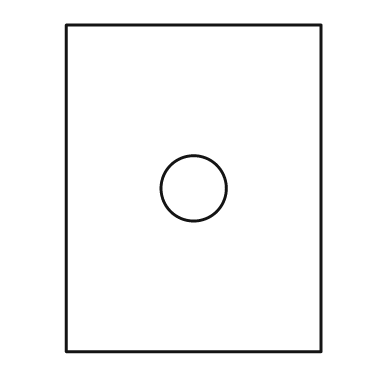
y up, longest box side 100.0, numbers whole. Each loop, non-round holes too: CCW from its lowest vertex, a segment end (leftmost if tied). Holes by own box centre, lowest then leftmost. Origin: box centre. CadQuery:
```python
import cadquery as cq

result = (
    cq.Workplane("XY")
    .moveTo(-39.0, -50.0)
    .lineTo(39.0, -50.0)
    .lineTo(39.0, 50.0)
    .lineTo(-39.0, 50.0)
    .close()
    .moveTo(0.0, 0.0)
    .circle(10.0)
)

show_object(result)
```